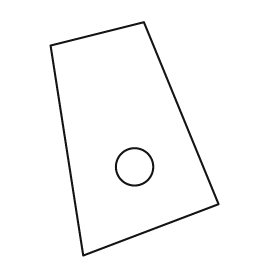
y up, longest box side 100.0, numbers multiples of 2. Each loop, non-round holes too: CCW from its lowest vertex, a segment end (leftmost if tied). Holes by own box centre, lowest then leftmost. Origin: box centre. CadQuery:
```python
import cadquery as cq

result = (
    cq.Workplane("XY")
    .moveTo(-22.0, -50.0)
    .lineTo(36.0, -28.0)
    .lineTo(4.0, 50.0)
    .lineTo(-36.0, 40.0)
    .close()
    .moveTo(0.0, -12.0)
    .circle(8.0)
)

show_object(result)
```